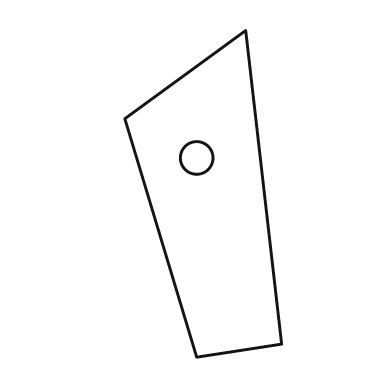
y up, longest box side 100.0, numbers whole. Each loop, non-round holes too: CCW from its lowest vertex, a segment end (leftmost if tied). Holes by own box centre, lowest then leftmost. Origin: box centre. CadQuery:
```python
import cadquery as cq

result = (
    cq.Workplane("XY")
    .moveTo(-2.0, -50.0)
    .lineTo(24.0, -46.0)
    .lineTo(13.0, 50.0)
    .lineTo(-24.0, 23.0)
    .close()
    .moveTo(-2.0, 11.0)
    .circle(5.0)
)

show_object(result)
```